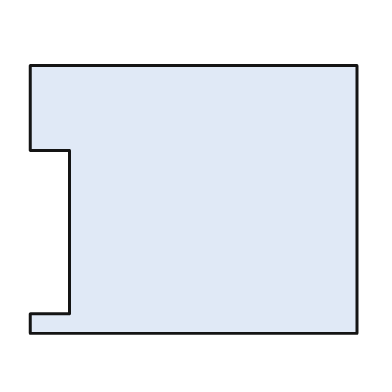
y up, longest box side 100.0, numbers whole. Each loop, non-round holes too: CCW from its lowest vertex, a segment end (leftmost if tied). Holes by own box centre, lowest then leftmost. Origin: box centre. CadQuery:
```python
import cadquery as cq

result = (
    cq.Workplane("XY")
    .moveTo(-50.0, -41.0)
    .lineTo(50.0, -41.0)
    .lineTo(50.0, 41.0)
    .lineTo(-50.0, 41.0)
    .lineTo(-50.0, 15.0)
    .lineTo(-38.0, 15.0)
    .lineTo(-38.0, -35.0)
    .lineTo(-50.0, -35.0)
    .close()
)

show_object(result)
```